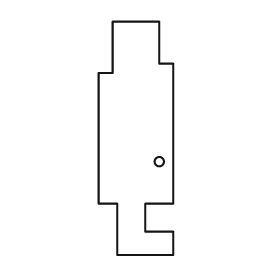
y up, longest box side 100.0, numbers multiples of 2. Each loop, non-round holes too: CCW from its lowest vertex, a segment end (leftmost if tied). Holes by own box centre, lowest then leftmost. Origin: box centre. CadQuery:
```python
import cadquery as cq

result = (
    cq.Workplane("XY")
    .moveTo(-8.0, -50.0)
    .lineTo(16.0, -50.0)
    .lineTo(16.0, -40.0)
    .lineTo(4.0, -40.0)
    .lineTo(4.0, -28.0)
    .lineTo(16.0, -28.0)
    .lineTo(16.0, 32.0)
    .lineTo(10.0, 32.0)
    .lineTo(10.0, 50.0)
    .lineTo(-10.0, 50.0)
    .lineTo(-10.0, 28.0)
    .lineTo(-16.0, 28.0)
    .lineTo(-16.0, -28.0)
    .lineTo(-8.0, -28.0)
    .close()
    .moveTo(10.0, -10.0)
    .circle(2.0)
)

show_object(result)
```